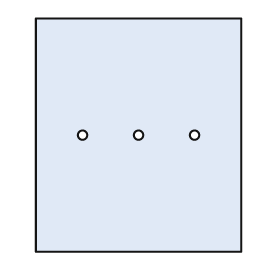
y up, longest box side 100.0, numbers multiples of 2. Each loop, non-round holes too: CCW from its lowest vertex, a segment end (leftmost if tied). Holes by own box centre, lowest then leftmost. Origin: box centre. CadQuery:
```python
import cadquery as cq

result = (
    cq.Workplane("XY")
    .moveTo(-44.0, -50.0)
    .lineTo(44.0, -50.0)
    .lineTo(44.0, 50.0)
    .lineTo(-44.0, 50.0)
    .close()
    .moveTo(-24.0, 0.0)
    .circle(2.0)
    .moveTo(0.0, 0.0)
    .circle(2.0)
    .moveTo(24.0, 0.0)
    .circle(2.0)
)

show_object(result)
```